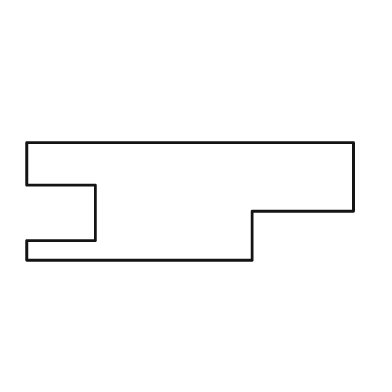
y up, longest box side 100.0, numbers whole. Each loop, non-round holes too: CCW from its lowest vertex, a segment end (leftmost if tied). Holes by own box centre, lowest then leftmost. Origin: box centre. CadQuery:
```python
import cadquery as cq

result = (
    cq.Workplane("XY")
    .moveTo(-50.0, -18.0)
    .lineTo(19.0, -18.0)
    .lineTo(19.0, -3.0)
    .lineTo(50.0, -3.0)
    .lineTo(50.0, 18.0)
    .lineTo(-50.0, 18.0)
    .lineTo(-50.0, 5.0)
    .lineTo(-29.0, 5.0)
    .lineTo(-29.0, -12.0)
    .lineTo(-50.0, -12.0)
    .close()
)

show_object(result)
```